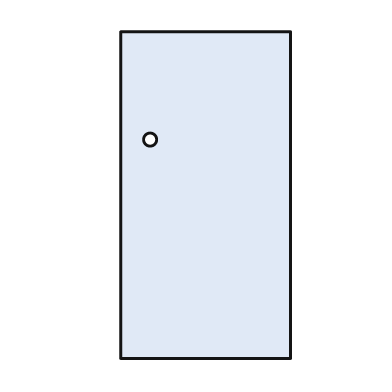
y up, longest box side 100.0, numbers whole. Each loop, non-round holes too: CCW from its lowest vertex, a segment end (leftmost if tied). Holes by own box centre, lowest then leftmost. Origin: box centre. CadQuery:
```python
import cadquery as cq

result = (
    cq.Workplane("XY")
    .moveTo(-26.0, -50.0)
    .lineTo(26.0, -50.0)
    .lineTo(26.0, 50.0)
    .lineTo(-26.0, 50.0)
    .close()
    .moveTo(-17.0, 17.0)
    .circle(2.0)
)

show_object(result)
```